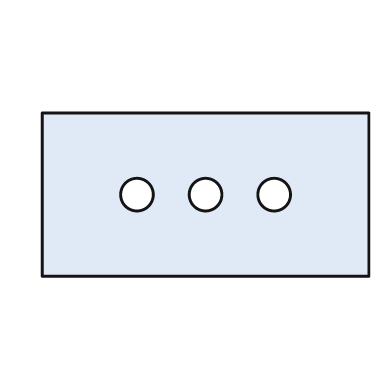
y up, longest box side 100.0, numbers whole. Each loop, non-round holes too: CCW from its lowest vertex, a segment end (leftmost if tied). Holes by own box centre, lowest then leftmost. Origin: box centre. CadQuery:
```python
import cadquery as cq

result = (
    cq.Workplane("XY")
    .moveTo(-50.0, -25.0)
    .lineTo(50.0, -25.0)
    .lineTo(50.0, 25.0)
    .lineTo(-50.0, 25.0)
    .close()
    .moveTo(-21.0, 0.0)
    .circle(5.0)
    .moveTo(0.0, 0.0)
    .circle(5.0)
    .moveTo(21.0, 0.0)
    .circle(5.0)
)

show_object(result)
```